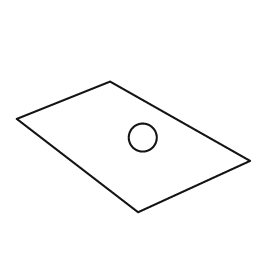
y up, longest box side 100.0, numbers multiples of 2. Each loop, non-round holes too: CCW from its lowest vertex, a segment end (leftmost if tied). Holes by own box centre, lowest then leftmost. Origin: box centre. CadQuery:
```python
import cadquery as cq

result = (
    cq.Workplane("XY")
    .moveTo(2.0, -28.0)
    .lineTo(50.0, -6.0)
    .lineTo(-10.0, 28.0)
    .lineTo(-50.0, 12.0)
    .close()
    .moveTo(4.0, 4.0)
    .circle(6.0)
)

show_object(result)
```